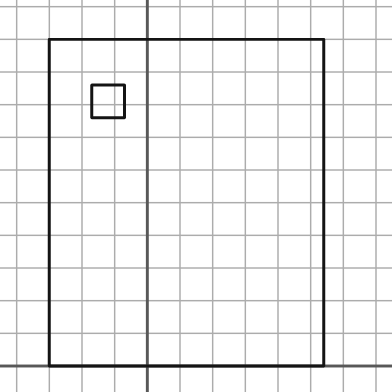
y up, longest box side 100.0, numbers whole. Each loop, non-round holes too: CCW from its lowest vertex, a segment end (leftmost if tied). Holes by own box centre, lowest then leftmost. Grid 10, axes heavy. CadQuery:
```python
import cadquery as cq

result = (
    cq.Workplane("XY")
    .moveTo(-30.0, 0.0)
    .lineTo(54.0, 0.0)
    .lineTo(54.0, 100.0)
    .lineTo(-30.0, 100.0)
    .close()
    .moveTo(-17.0, 76.0)
    .lineTo(-7.0, 76.0)
    .lineTo(-7.0, 86.0)
    .lineTo(-17.0, 86.0)
    .close()
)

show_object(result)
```